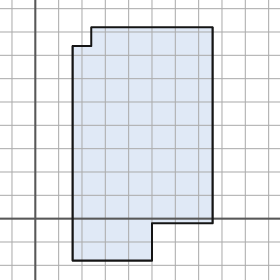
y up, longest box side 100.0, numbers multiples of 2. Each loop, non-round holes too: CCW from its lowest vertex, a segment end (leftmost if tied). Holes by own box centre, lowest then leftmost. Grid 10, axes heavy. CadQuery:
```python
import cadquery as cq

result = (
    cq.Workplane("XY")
    .moveTo(16.0, -18.0)
    .lineTo(50.0, -18.0)
    .lineTo(50.0, -2.0)
    .lineTo(76.0, -2.0)
    .lineTo(76.0, 82.0)
    .lineTo(24.0, 82.0)
    .lineTo(24.0, 74.0)
    .lineTo(16.0, 74.0)
    .close()
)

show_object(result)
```